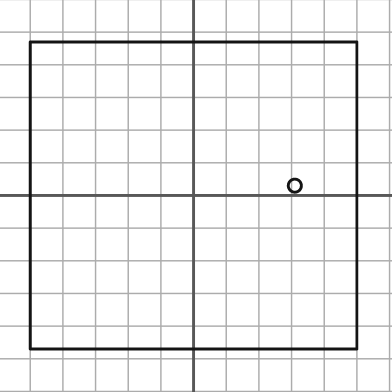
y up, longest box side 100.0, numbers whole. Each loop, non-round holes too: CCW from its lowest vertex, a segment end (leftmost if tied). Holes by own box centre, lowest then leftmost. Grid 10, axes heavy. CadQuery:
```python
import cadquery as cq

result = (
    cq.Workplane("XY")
    .moveTo(-50.0, -47.0)
    .lineTo(50.0, -47.0)
    .lineTo(50.0, 47.0)
    .lineTo(-50.0, 47.0)
    .close()
    .moveTo(31.0, 3.0)
    .circle(2.0)
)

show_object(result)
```